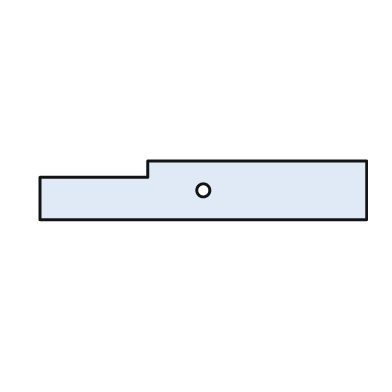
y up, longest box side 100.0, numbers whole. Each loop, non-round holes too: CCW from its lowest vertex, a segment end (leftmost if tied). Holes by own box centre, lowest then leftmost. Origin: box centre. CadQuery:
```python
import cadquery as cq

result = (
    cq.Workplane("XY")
    .moveTo(-50.0, -9.0)
    .lineTo(50.0, -9.0)
    .lineTo(50.0, 9.0)
    .lineTo(-17.0, 9.0)
    .lineTo(-17.0, 4.0)
    .lineTo(-50.0, 4.0)
    .close()
    .moveTo(0.0, 0.0)
    .circle(2.0)
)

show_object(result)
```